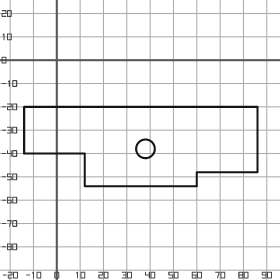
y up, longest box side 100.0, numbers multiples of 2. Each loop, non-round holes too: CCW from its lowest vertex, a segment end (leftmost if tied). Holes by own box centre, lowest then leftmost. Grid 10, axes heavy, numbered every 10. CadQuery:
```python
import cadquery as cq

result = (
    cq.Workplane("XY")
    .moveTo(12.0, -54.0)
    .lineTo(60.0, -54.0)
    .lineTo(60.0, -48.0)
    .lineTo(86.0, -48.0)
    .lineTo(86.0, -20.0)
    .lineTo(-14.0, -20.0)
    .lineTo(-14.0, -40.0)
    .lineTo(12.0, -40.0)
    .close()
    .moveTo(38.0, -38.0)
    .circle(4.0)
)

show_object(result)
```